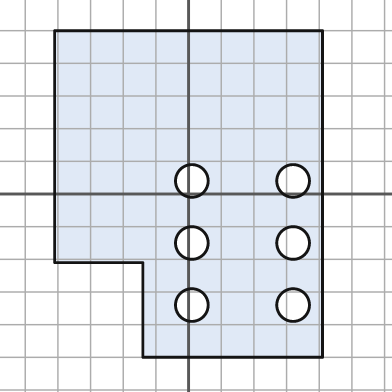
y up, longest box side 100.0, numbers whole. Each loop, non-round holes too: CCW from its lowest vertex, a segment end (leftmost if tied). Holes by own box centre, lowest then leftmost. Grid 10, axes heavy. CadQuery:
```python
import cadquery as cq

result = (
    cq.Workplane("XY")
    .moveTo(-14.0, -50.0)
    .lineTo(41.0, -50.0)
    .lineTo(41.0, 50.0)
    .lineTo(-41.0, 50.0)
    .lineTo(-41.0, -21.0)
    .lineTo(-14.0, -21.0)
    .close()
    .moveTo(1.0, -34.0)
    .circle(5.0)
    .moveTo(32.0, -34.0)
    .circle(5.0)
    .moveTo(1.0, -15.0)
    .circle(5.0)
    .moveTo(32.0, -15.0)
    .circle(5.0)
    .moveTo(1.0, 4.0)
    .circle(5.0)
    .moveTo(32.0, 4.0)
    .circle(5.0)
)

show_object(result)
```